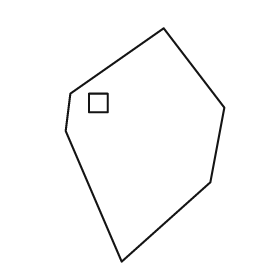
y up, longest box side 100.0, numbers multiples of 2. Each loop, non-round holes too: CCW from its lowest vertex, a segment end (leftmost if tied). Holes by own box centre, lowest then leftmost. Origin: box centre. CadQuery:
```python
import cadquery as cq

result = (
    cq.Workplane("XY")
    .moveTo(-10.0, -50.0)
    .lineTo(28.0, -16.0)
    .lineTo(34.0, 16.0)
    .lineTo(8.0, 50.0)
    .lineTo(-32.0, 22.0)
    .lineTo(-34.0, 6.0)
    .close()
    .moveTo(-24.0, 14.0)
    .lineTo(-16.0, 14.0)
    .lineTo(-16.0, 22.0)
    .lineTo(-24.0, 22.0)
    .close()
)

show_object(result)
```